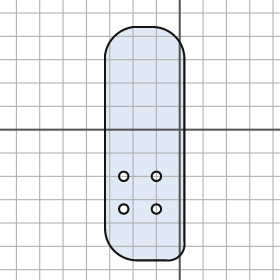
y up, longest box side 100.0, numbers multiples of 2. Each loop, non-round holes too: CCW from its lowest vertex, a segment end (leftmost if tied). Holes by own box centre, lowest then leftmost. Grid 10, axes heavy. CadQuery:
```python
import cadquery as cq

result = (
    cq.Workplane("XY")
    .moveTo(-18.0, -56.0)
    .lineTo(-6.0, -56.0)
    .threePointArc((0.0, -54.0), (2.0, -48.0))
    .lineTo(2.0, 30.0)
    .threePointArc((-2.0, 40.0), (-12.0, 44.0))
    .lineTo(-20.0, 44.0)
    .threePointArc((-28.0, 40.0), (-32.0, 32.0))
    .lineTo(-32.0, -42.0)
    .threePointArc((-28.0, -52.0), (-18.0, -56.0))
    .close()
    .moveTo(-24.0, -34.0)
    .circle(2.0)
    .moveTo(-10.0, -34.0)
    .circle(2.0)
    .moveTo(-24.0, -20.0)
    .circle(2.0)
    .moveTo(-10.0, -20.0)
    .circle(2.0)
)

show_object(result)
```